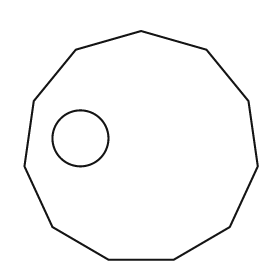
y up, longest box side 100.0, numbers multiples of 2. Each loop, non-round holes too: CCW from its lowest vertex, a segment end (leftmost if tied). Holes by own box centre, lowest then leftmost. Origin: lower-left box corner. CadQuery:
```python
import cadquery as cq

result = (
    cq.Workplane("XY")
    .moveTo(36.0, 0.0)
    .lineTo(64.0, 0.0)
    .lineTo(88.0, 14.0)
    .lineTo(100.0, 40.0)
    .lineTo(96.0, 68.0)
    .lineTo(78.0, 90.0)
    .lineTo(50.0, 98.0)
    .lineTo(22.0, 90.0)
    .lineTo(4.0, 68.0)
    .lineTo(0.0, 40.0)
    .lineTo(12.0, 14.0)
    .close()
    .moveTo(24.0, 52.0)
    .circle(12.0)
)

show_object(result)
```